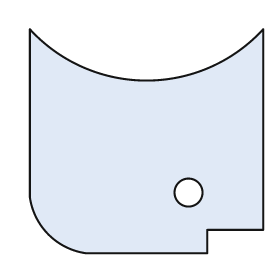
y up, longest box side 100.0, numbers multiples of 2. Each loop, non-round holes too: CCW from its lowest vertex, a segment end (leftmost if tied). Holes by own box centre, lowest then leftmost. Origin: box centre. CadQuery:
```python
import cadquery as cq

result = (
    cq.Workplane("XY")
    .moveTo(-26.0, -48.0)
    .lineTo(26.0, -48.0)
    .lineTo(26.0, -38.0)
    .lineTo(50.0, -38.0)
    .lineTo(50.0, 48.0)
    .threePointArc((0.0, 26.0), (-50.0, 48.0))
    .lineTo(-50.0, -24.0)
    .threePointArc((-42.0, -40.0), (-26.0, -48.0))
    .close()
    .moveTo(18.0, -22.0)
    .circle(6.0)
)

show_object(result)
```